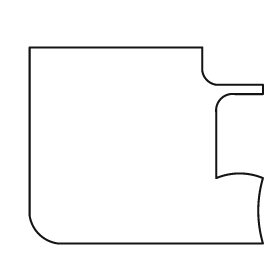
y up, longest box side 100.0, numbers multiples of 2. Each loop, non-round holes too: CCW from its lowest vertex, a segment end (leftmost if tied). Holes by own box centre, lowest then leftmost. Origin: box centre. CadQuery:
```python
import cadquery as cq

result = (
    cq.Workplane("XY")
    .moveTo(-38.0, -42.0)
    .lineTo(50.0, -42.0)
    .threePointArc((48.0, -28.0), (50.0, -14.0))
    .threePointArc((40.0, -12.0), (30.0, -14.0))
    .lineTo(30.0, 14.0)
    .threePointArc((32.0, 20.0), (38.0, 22.0))
    .lineTo(50.0, 22.0)
    .lineTo(50.0, 26.0)
    .lineTo(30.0, 26.0)
    .threePointArc((26.0, 28.0), (24.0, 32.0))
    .lineTo(24.0, 42.0)
    .lineTo(-50.0, 42.0)
    .lineTo(-50.0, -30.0)
    .threePointArc((-46.0, -38.0), (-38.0, -42.0))
    .close()
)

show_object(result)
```